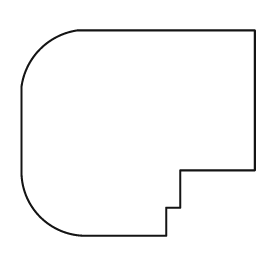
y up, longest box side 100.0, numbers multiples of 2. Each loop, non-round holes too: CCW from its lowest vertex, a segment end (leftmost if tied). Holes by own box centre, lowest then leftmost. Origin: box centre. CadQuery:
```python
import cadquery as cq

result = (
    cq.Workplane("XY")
    .moveTo(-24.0, -44.0)
    .lineTo(12.0, -44.0)
    .lineTo(12.0, -32.0)
    .lineTo(18.0, -32.0)
    .lineTo(18.0, -16.0)
    .lineTo(50.0, -16.0)
    .lineTo(50.0, 44.0)
    .lineTo(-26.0, 44.0)
    .threePointArc((-42.0, 36.0), (-50.0, 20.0))
    .lineTo(-50.0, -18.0)
    .threePointArc((-42.0, -36.0), (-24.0, -44.0))
    .close()
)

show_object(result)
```